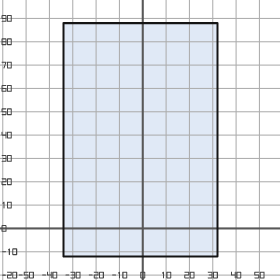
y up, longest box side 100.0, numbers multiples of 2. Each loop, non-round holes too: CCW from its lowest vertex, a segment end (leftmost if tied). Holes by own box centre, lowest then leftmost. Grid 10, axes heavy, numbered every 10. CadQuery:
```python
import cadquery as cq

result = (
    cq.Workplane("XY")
    .moveTo(-34.0, -12.0)
    .lineTo(32.0, -12.0)
    .lineTo(32.0, 88.0)
    .lineTo(-34.0, 88.0)
    .close()
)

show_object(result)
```